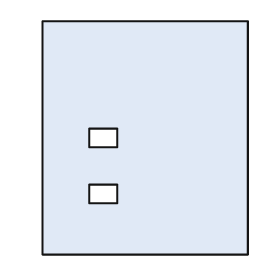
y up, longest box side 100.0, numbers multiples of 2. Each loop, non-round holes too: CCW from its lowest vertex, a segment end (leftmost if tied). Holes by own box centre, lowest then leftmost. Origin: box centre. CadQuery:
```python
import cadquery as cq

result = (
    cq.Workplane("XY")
    .moveTo(-44.0, -50.0)
    .lineTo(44.0, -50.0)
    .lineTo(44.0, 50.0)
    .lineTo(-44.0, 50.0)
    .close()
    .moveTo(-24.0, -28.0)
    .lineTo(-12.0, -28.0)
    .lineTo(-12.0, -20.0)
    .lineTo(-24.0, -20.0)
    .close()
    .moveTo(-24.0, -4.0)
    .lineTo(-12.0, -4.0)
    .lineTo(-12.0, 4.0)
    .lineTo(-24.0, 4.0)
    .close()
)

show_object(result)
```